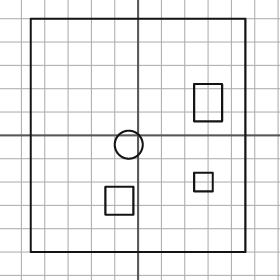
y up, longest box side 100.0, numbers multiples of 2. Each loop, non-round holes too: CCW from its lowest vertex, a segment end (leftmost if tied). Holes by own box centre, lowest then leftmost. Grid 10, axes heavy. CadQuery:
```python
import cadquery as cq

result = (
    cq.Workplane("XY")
    .moveTo(-46.0, -50.0)
    .lineTo(46.0, -50.0)
    .lineTo(46.0, 50.0)
    .lineTo(-46.0, 50.0)
    .close()
    .moveTo(-14.0, -34.0)
    .lineTo(-2.0, -34.0)
    .lineTo(-2.0, -22.0)
    .lineTo(-14.0, -22.0)
    .close()
    .moveTo(24.0, -24.0)
    .lineTo(32.0, -24.0)
    .lineTo(32.0, -16.0)
    .lineTo(24.0, -16.0)
    .close()
    .moveTo(-4.0, -4.0)
    .circle(6.0)
    .moveTo(24.0, 6.0)
    .lineTo(36.0, 6.0)
    .lineTo(36.0, 22.0)
    .lineTo(24.0, 22.0)
    .close()
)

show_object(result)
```